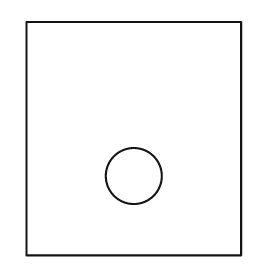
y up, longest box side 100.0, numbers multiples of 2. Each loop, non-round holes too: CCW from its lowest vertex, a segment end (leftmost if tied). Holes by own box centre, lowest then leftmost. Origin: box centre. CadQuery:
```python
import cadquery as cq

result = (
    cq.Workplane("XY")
    .moveTo(-46.0, -50.0)
    .lineTo(46.0, -50.0)
    .lineTo(46.0, 50.0)
    .lineTo(-46.0, 50.0)
    .close()
    .moveTo(0.0, -16.0)
    .circle(12.0)
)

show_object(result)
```